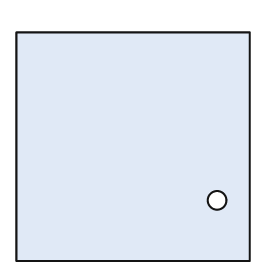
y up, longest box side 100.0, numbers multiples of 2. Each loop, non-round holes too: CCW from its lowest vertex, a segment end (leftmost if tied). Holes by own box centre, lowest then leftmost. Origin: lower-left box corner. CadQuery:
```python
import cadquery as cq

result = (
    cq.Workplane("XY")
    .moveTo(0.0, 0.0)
    .lineTo(100.0, 0.0)
    .lineTo(100.0, 98.0)
    .lineTo(0.0, 98.0)
    .close()
    .moveTo(86.0, 26.0)
    .circle(4.0)
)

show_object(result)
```